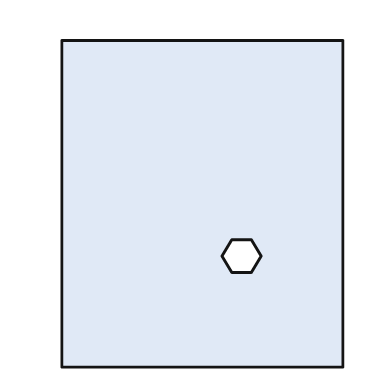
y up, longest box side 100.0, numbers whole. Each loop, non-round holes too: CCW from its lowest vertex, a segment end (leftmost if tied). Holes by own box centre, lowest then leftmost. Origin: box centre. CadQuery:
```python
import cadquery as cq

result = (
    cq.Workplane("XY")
    .moveTo(-43.0, -50.0)
    .lineTo(43.0, -50.0)
    .lineTo(43.0, 50.0)
    .lineTo(-43.0, 50.0)
    .close()
    .moveTo(9.0, -21.0)
    .lineTo(15.0, -21.0)
    .lineTo(18.0, -16.0)
    .lineTo(15.0, -11.0)
    .lineTo(9.0, -11.0)
    .lineTo(6.0, -16.0)
    .close()
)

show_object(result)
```